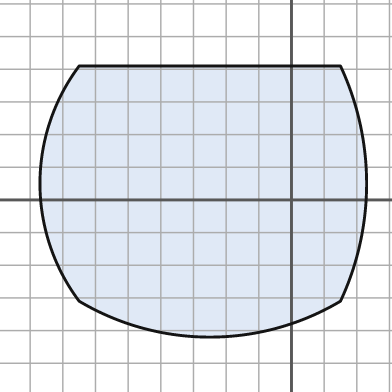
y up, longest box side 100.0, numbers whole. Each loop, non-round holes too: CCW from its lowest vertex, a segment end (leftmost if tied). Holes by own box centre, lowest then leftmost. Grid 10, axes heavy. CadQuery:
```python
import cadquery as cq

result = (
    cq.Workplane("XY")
    .moveTo(-65.0, -31.0)
    .threePointArc((-25.0, -42.0), (15.0, -31.0))
    .threePointArc((23.0, 5.0), (15.0, 41.0))
    .lineTo(-65.0, 41.0)
    .threePointArc((-77.0, 5.0), (-65.0, -31.0))
    .close()
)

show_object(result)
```